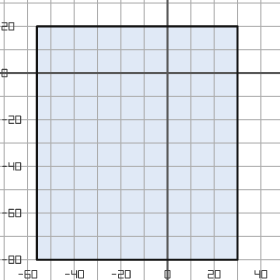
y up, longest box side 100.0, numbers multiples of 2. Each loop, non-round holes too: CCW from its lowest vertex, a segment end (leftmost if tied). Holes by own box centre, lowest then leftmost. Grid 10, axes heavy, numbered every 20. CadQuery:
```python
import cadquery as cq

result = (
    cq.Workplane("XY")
    .moveTo(-56.0, -80.0)
    .lineTo(30.0, -80.0)
    .lineTo(30.0, 20.0)
    .lineTo(-56.0, 20.0)
    .close()
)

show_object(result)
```